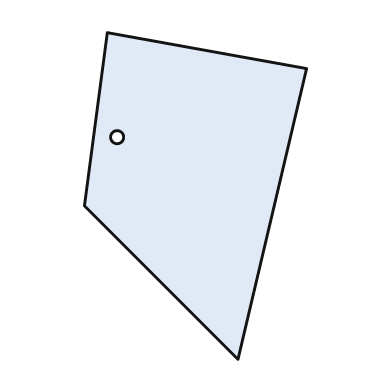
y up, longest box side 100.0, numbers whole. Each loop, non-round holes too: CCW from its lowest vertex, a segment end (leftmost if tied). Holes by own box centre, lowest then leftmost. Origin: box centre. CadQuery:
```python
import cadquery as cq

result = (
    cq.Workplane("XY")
    .moveTo(13.0, -50.0)
    .lineTo(34.0, 39.0)
    .lineTo(-27.0, 50.0)
    .lineTo(-34.0, -3.0)
    .close()
    .moveTo(-24.0, 18.0)
    .circle(2.0)
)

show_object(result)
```